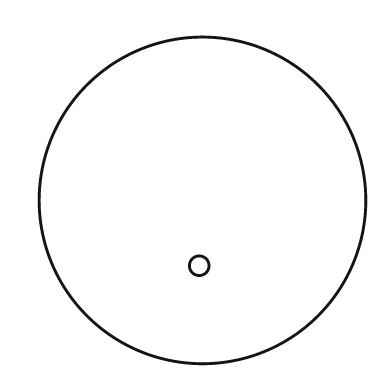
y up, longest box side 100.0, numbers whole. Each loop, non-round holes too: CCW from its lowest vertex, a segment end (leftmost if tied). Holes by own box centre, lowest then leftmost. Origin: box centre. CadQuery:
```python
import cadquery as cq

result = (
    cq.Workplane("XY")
    .moveTo(0.0, 0.0)
    .circle(50.0)
    .moveTo(-1.0, -20.0)
    .circle(3.0)
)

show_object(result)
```